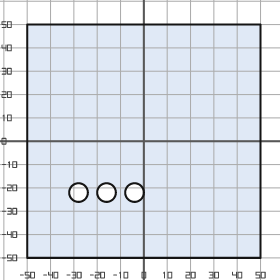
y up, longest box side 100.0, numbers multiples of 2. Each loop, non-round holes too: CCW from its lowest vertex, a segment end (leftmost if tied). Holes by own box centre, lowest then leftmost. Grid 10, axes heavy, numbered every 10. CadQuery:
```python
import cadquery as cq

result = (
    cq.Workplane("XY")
    .moveTo(-50.0, -50.0)
    .lineTo(50.0, -50.0)
    .lineTo(50.0, 50.0)
    .lineTo(-50.0, 50.0)
    .close()
    .moveTo(-28.0, -22.0)
    .circle(4.0)
    .moveTo(-16.0, -22.0)
    .circle(4.0)
    .moveTo(-4.0, -22.0)
    .circle(4.0)
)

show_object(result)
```